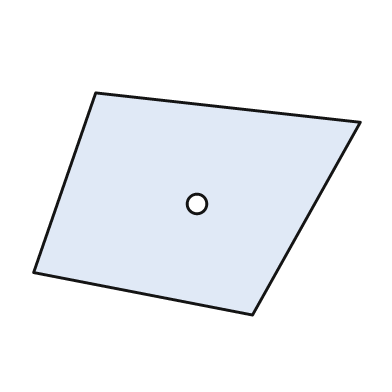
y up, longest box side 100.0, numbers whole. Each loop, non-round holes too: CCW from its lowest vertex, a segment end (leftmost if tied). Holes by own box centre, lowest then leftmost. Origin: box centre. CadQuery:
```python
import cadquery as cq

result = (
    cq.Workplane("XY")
    .moveTo(17.0, -34.0)
    .lineTo(50.0, 25.0)
    .lineTo(-31.0, 34.0)
    .lineTo(-50.0, -21.0)
    .close()
    .moveTo(0.0, 0.0)
    .circle(3.0)
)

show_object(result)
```